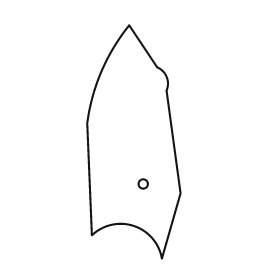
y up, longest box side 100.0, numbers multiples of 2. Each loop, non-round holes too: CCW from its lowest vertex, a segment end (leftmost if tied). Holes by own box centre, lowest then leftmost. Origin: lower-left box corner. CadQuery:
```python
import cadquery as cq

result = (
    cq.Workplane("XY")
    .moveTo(32.0, 0.0)
    .lineTo(40.0, 28.0)
    .lineTo(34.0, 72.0)
    .threePointArc((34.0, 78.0), (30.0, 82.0))
    .lineTo(18.0, 100.0)
    .threePointArc((6.0, 80.0), (0.0, 58.0))
    .lineTo(2.0, 10.0)
    .threePointArc((20.0, 14.0), (32.0, 0.0))
    .close()
    .moveTo(24.0, 32.0)
    .circle(2.0)
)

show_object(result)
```